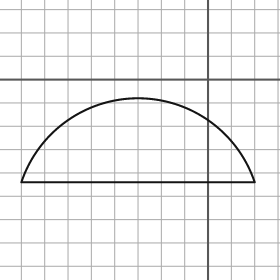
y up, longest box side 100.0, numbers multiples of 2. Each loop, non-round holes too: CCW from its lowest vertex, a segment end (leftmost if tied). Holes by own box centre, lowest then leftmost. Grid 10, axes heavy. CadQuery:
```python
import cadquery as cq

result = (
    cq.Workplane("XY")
    .moveTo(-80.0, -44.0)
    .lineTo(20.0, -44.0)
    .threePointArc((-30.0, -8.0), (-80.0, -44.0))
    .close()
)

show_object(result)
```